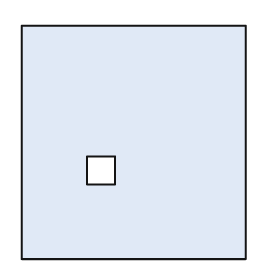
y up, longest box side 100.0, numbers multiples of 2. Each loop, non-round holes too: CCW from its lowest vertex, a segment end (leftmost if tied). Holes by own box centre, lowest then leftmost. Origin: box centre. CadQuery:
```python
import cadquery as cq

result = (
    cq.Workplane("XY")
    .moveTo(-48.0, -50.0)
    .lineTo(48.0, -50.0)
    .lineTo(48.0, 50.0)
    .lineTo(-48.0, 50.0)
    .close()
    .moveTo(-20.0, -18.0)
    .lineTo(-8.0, -18.0)
    .lineTo(-8.0, -6.0)
    .lineTo(-20.0, -6.0)
    .close()
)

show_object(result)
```